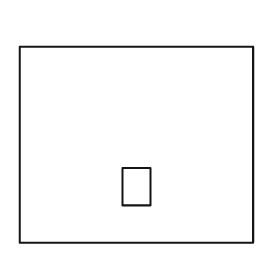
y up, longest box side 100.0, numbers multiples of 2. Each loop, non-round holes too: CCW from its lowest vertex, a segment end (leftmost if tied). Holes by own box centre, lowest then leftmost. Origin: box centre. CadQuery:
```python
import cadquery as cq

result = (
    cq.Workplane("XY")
    .moveTo(-50.0, -42.0)
    .lineTo(50.0, -42.0)
    .lineTo(50.0, 42.0)
    .lineTo(-50.0, 42.0)
    .close()
    .moveTo(-6.0, -26.0)
    .lineTo(6.0, -26.0)
    .lineTo(6.0, -10.0)
    .lineTo(-6.0, -10.0)
    .close()
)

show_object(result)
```